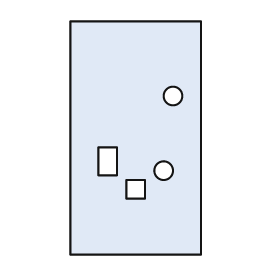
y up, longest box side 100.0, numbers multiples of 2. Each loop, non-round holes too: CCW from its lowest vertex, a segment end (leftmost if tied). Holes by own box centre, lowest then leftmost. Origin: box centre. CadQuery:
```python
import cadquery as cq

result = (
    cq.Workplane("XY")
    .moveTo(-28.0, -50.0)
    .lineTo(28.0, -50.0)
    .lineTo(28.0, 50.0)
    .lineTo(-28.0, 50.0)
    .close()
    .moveTo(-4.0, -26.0)
    .lineTo(4.0, -26.0)
    .lineTo(4.0, -18.0)
    .lineTo(-4.0, -18.0)
    .close()
    .moveTo(12.0, -14.0)
    .circle(4.0)
    .moveTo(-16.0, -16.0)
    .lineTo(-8.0, -16.0)
    .lineTo(-8.0, -4.0)
    .lineTo(-16.0, -4.0)
    .close()
    .moveTo(16.0, 18.0)
    .circle(4.0)
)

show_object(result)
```